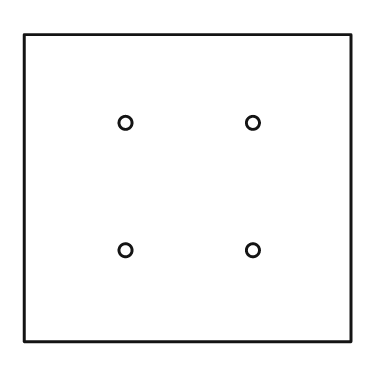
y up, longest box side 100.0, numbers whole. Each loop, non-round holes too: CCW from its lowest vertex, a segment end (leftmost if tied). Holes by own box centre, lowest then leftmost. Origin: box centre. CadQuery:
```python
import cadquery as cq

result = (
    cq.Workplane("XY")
    .moveTo(-50.0, -47.0)
    .lineTo(50.0, -47.0)
    .lineTo(50.0, 47.0)
    .lineTo(-50.0, 47.0)
    .close()
    .moveTo(-19.0, -19.0)
    .circle(2.0)
    .moveTo(20.0, -19.0)
    .circle(2.0)
    .moveTo(-19.0, 20.0)
    .circle(2.0)
    .moveTo(20.0, 20.0)
    .circle(2.0)
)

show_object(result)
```